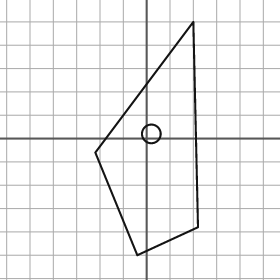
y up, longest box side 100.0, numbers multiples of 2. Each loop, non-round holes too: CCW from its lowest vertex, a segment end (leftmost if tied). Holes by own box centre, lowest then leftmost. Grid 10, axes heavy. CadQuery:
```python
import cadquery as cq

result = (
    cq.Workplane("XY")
    .moveTo(-4.0, -50.0)
    .lineTo(22.0, -38.0)
    .lineTo(20.0, 50.0)
    .lineTo(-22.0, -6.0)
    .close()
    .moveTo(2.0, 2.0)
    .circle(4.0)
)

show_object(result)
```